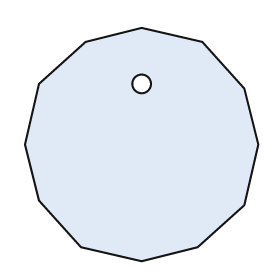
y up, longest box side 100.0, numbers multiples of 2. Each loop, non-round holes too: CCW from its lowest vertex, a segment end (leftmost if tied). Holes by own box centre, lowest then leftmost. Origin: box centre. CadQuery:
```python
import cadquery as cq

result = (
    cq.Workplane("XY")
    .moveTo(0.0, -50.0)
    .lineTo(24.0, -44.0)
    .lineTo(44.0, -26.0)
    .lineTo(50.0, 0.0)
    .lineTo(44.0, 24.0)
    .lineTo(26.0, 44.0)
    .lineTo(0.0, 50.0)
    .lineTo(-24.0, 44.0)
    .lineTo(-44.0, 26.0)
    .lineTo(-50.0, 0.0)
    .lineTo(-44.0, -24.0)
    .lineTo(-26.0, -44.0)
    .close()
    .moveTo(0.0, 26.0)
    .circle(4.0)
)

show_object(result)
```